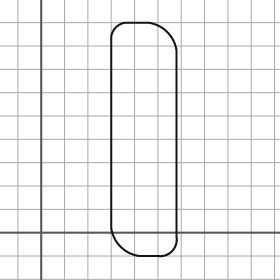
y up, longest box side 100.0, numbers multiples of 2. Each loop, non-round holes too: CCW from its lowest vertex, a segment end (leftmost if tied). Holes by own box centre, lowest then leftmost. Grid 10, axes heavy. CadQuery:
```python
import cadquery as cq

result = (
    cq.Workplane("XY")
    .moveTo(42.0, -10.0)
    .lineTo(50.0, -10.0)
    .threePointArc((56.0, -8.0), (58.0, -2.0))
    .lineTo(58.0, 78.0)
    .threePointArc((54.0, 86.0), (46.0, 90.0))
    .lineTo(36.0, 90.0)
    .threePointArc((32.0, 88.0), (30.0, 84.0))
    .lineTo(30.0, 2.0)
    .threePointArc((34.0, -6.0), (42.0, -10.0))
    .close()
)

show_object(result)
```